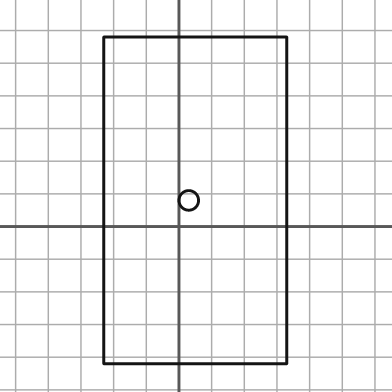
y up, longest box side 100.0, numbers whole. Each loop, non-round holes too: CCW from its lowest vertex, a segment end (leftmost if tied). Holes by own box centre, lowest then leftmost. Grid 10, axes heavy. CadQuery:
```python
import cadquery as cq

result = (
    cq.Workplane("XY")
    .moveTo(-23.0, -42.0)
    .lineTo(33.0, -42.0)
    .lineTo(33.0, 58.0)
    .lineTo(-23.0, 58.0)
    .close()
    .moveTo(3.0, 8.0)
    .circle(3.0)
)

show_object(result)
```